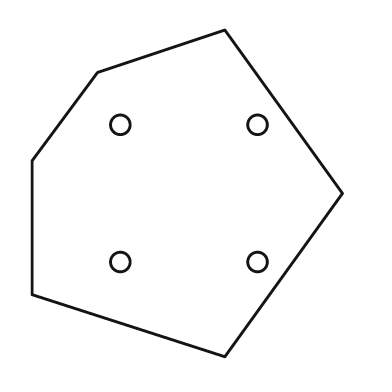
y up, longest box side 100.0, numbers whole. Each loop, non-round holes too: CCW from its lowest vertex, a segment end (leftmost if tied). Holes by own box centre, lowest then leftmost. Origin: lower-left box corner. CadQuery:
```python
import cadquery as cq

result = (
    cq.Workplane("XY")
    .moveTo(59.0, 0.0)
    .lineTo(95.0, 50.0)
    .lineTo(59.0, 100.0)
    .lineTo(20.0, 87.0)
    .lineTo(0.0, 60.0)
    .lineTo(0.0, 19.0)
    .close()
    .moveTo(27.0, 29.0)
    .circle(3.0)
    .moveTo(69.0, 29.0)
    .circle(3.0)
    .moveTo(27.0, 71.0)
    .circle(3.0)
    .moveTo(69.0, 71.0)
    .circle(3.0)
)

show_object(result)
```